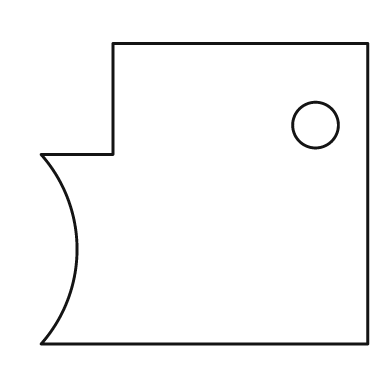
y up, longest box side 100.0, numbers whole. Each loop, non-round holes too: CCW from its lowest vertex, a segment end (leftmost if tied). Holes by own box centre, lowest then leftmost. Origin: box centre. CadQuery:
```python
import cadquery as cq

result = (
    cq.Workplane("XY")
    .moveTo(-50.0, -46.0)
    .lineTo(50.0, -46.0)
    .lineTo(50.0, 46.0)
    .lineTo(-28.0, 46.0)
    .lineTo(-28.0, 12.0)
    .lineTo(-50.0, 12.0)
    .threePointArc((-39.0, -17.0), (-50.0, -46.0))
    .close()
    .moveTo(34.0, 21.0)
    .circle(7.0)
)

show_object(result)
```